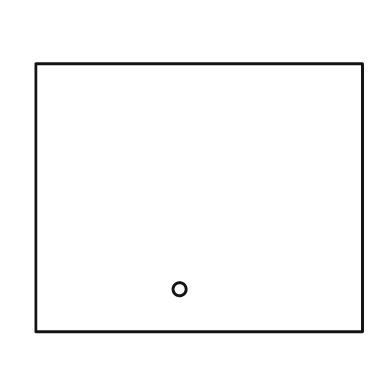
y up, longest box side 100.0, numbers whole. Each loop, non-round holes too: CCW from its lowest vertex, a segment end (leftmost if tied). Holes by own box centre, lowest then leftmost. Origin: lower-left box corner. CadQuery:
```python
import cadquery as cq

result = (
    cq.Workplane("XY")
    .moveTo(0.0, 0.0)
    .lineTo(100.0, 0.0)
    .lineTo(100.0, 82.0)
    .lineTo(0.0, 82.0)
    .close()
    .moveTo(44.0, 13.0)
    .circle(2.0)
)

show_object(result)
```